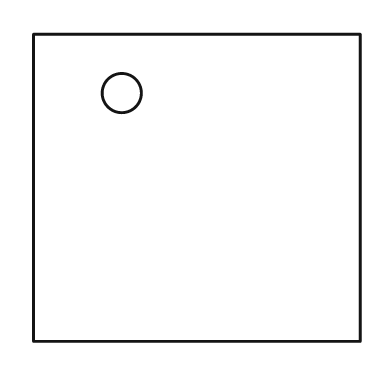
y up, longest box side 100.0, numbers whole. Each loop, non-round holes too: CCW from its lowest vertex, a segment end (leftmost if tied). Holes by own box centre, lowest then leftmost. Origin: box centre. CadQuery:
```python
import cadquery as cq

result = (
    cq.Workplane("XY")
    .moveTo(-50.0, -47.0)
    .lineTo(50.0, -47.0)
    .lineTo(50.0, 47.0)
    .lineTo(-50.0, 47.0)
    .close()
    .moveTo(-23.0, 29.0)
    .circle(6.0)
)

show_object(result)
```